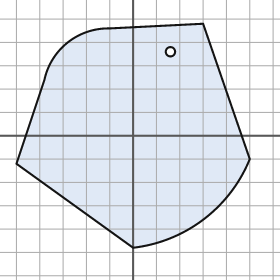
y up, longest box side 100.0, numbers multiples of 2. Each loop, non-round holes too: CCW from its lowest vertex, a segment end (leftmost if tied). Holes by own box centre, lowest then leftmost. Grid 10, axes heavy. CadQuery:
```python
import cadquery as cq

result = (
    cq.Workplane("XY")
    .moveTo(0.0, -48.0)
    .threePointArc((30.0, -36.0), (50.0, -10.0))
    .lineTo(30.0, 48.0)
    .lineTo(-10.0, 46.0)
    .threePointArc((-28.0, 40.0), (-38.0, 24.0))
    .lineTo(-50.0, -12.0)
    .close()
    .moveTo(16.0, 36.0)
    .circle(2.0)
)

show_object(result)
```